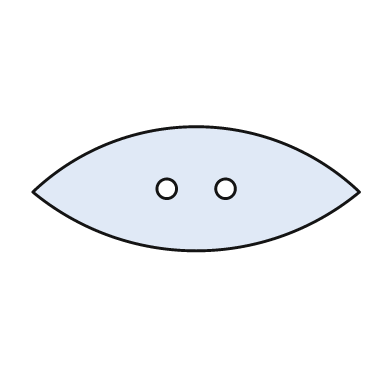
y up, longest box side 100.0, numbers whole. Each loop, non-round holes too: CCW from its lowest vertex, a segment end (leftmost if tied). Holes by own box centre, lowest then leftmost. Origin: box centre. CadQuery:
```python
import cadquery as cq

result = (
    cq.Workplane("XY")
    .moveTo(-50.0, -1.0)
    .threePointArc((0.0, -19.0), (50.0, -1.0))
    .threePointArc((0.0, 19.0), (-50.0, -1.0))
    .close()
    .moveTo(-9.0, 0.0)
    .circle(3.0)
    .moveTo(9.0, 0.0)
    .circle(3.0)
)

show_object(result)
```